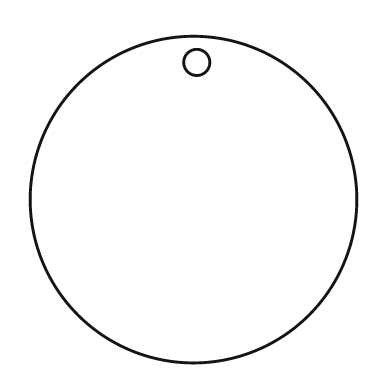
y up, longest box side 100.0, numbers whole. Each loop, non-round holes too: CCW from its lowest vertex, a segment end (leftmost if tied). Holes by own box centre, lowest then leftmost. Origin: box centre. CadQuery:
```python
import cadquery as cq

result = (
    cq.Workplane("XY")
    .moveTo(0.0, 0.0)
    .circle(50.0)
    .moveTo(1.0, 42.0)
    .circle(4.0)
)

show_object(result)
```